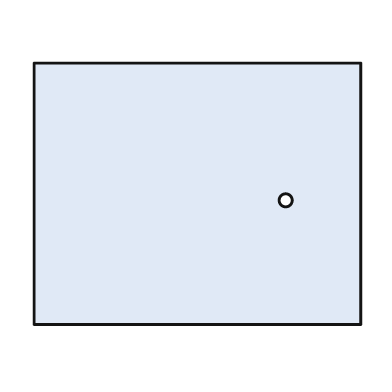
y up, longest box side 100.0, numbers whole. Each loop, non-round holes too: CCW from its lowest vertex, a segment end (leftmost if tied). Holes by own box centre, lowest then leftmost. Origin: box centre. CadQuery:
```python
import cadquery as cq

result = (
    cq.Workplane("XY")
    .moveTo(-50.0, -40.0)
    .lineTo(50.0, -40.0)
    .lineTo(50.0, 40.0)
    .lineTo(-50.0, 40.0)
    .close()
    .moveTo(27.0, -2.0)
    .circle(2.0)
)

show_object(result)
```